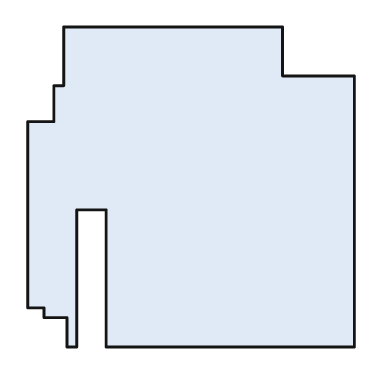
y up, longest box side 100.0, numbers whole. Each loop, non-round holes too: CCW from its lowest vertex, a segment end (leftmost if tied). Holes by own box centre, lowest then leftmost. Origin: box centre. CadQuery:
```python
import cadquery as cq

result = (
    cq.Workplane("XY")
    .moveTo(-38.0, -49.0)
    .lineTo(-35.0, -49.0)
    .lineTo(-35.0, -7.0)
    .lineTo(-26.0, -7.0)
    .lineTo(-26.0, -49.0)
    .lineTo(50.0, -49.0)
    .lineTo(50.0, 34.0)
    .lineTo(28.0, 34.0)
    .lineTo(28.0, 49.0)
    .lineTo(-39.0, 49.0)
    .lineTo(-39.0, 31.0)
    .lineTo(-42.0, 31.0)
    .lineTo(-42.0, 20.0)
    .lineTo(-50.0, 20.0)
    .lineTo(-50.0, -37.0)
    .lineTo(-45.0, -37.0)
    .lineTo(-45.0, -40.0)
    .lineTo(-38.0, -40.0)
    .close()
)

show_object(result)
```